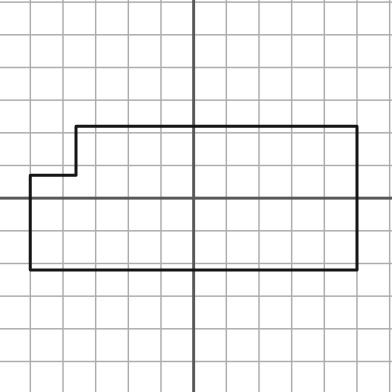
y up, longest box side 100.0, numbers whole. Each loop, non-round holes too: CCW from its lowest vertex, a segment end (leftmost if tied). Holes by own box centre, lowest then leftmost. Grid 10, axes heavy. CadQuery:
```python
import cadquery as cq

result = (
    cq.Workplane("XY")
    .moveTo(-50.0, -22.0)
    .lineTo(50.0, -22.0)
    .lineTo(50.0, 22.0)
    .lineTo(-36.0, 22.0)
    .lineTo(-36.0, 7.0)
    .lineTo(-50.0, 7.0)
    .close()
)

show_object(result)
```